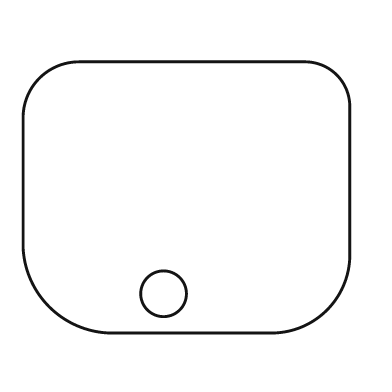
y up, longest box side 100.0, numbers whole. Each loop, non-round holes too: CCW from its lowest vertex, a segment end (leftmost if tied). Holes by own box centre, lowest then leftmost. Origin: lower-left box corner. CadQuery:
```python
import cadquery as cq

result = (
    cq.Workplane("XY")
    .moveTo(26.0, 0.0)
    .lineTo(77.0, 0.0)
    .threePointArc((93.0, 7.0), (100.0, 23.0))
    .lineTo(100.0, 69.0)
    .threePointArc((96.0, 79.0), (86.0, 83.0))
    .lineTo(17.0, 83.0)
    .threePointArc((5.0, 78.0), (0.0, 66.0))
    .lineTo(0.0, 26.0)
    .threePointArc((8.0, 8.0), (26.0, 0.0))
    .close()
    .moveTo(43.0, 12.0)
    .circle(7.0)
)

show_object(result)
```